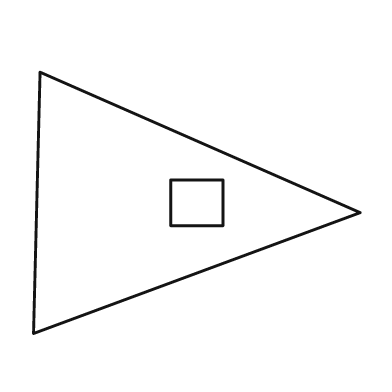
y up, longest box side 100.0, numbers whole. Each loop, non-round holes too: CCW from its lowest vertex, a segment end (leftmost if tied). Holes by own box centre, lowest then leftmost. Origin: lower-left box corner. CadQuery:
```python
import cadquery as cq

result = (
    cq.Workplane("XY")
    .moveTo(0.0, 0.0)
    .lineTo(100.0, 37.0)
    .lineTo(2.0, 80.0)
    .close()
    .moveTo(42.0, 33.0)
    .lineTo(58.0, 33.0)
    .lineTo(58.0, 47.0)
    .lineTo(42.0, 47.0)
    .close()
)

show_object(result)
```